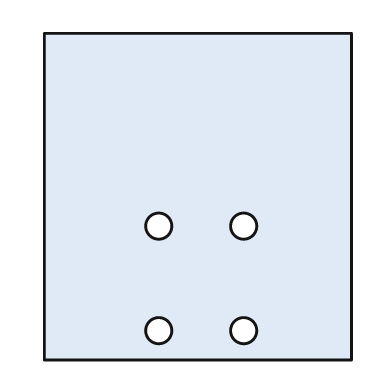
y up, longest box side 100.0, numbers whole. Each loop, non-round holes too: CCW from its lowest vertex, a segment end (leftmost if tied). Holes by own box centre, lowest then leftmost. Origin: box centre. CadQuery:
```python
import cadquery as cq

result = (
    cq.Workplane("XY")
    .moveTo(-47.0, -50.0)
    .lineTo(47.0, -50.0)
    .lineTo(47.0, 50.0)
    .lineTo(-47.0, 50.0)
    .close()
    .moveTo(-12.0, -41.0)
    .circle(4.0)
    .moveTo(14.0, -41.0)
    .circle(4.0)
    .moveTo(-12.0, -9.0)
    .circle(4.0)
    .moveTo(14.0, -9.0)
    .circle(4.0)
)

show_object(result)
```